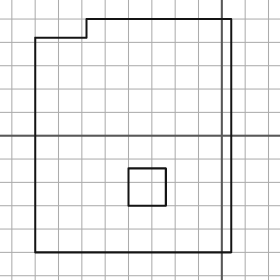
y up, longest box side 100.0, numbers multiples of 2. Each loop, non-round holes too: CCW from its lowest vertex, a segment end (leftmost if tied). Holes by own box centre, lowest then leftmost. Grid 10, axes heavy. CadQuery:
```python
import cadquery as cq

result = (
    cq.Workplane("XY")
    .moveTo(-80.0, -50.0)
    .lineTo(4.0, -50.0)
    .lineTo(4.0, 50.0)
    .lineTo(-58.0, 50.0)
    .lineTo(-58.0, 42.0)
    .lineTo(-80.0, 42.0)
    .close()
    .moveTo(-40.0, -30.0)
    .lineTo(-24.0, -30.0)
    .lineTo(-24.0, -14.0)
    .lineTo(-40.0, -14.0)
    .close()
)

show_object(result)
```